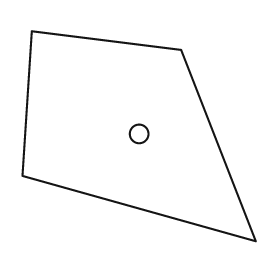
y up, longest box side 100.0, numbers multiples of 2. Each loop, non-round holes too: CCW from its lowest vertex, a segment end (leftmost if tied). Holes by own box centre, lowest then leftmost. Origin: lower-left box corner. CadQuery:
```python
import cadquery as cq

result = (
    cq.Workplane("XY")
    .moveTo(100.0, 0.0)
    .lineTo(68.0, 82.0)
    .lineTo(4.0, 90.0)
    .lineTo(0.0, 28.0)
    .close()
    .moveTo(50.0, 46.0)
    .circle(4.0)
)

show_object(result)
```